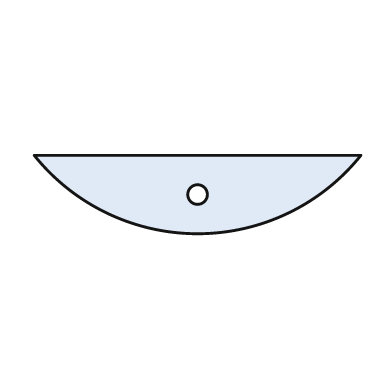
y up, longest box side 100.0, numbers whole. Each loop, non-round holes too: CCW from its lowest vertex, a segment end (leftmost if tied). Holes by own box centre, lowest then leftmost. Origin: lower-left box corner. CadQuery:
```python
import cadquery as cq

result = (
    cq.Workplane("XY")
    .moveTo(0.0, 24.0)
    .threePointArc((50.0, 0.0), (100.0, 24.0))
    .close()
    .moveTo(50.0, 12.0)
    .circle(3.0)
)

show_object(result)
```